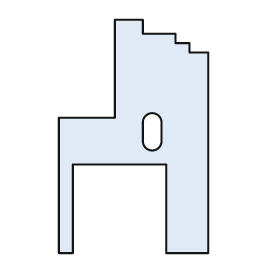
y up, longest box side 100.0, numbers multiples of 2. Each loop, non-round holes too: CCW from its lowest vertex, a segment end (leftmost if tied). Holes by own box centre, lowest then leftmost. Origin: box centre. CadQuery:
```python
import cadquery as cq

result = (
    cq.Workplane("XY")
    .moveTo(-32.0, -50.0)
    .lineTo(-26.0, -50.0)
    .lineTo(-26.0, -12.0)
    .lineTo(14.0, -12.0)
    .lineTo(14.0, -50.0)
    .lineTo(32.0, -50.0)
    .lineTo(32.0, 36.0)
    .lineTo(24.0, 36.0)
    .lineTo(24.0, 40.0)
    .lineTo(18.0, 40.0)
    .lineTo(18.0, 44.0)
    .lineTo(4.0, 44.0)
    .lineTo(4.0, 50.0)
    .lineTo(-8.0, 50.0)
    .lineTo(-8.0, 8.0)
    .lineTo(-32.0, 8.0)
    .close()
    .moveTo(4.0, -2.0)
    .threePointArc((8.0, -6.0), (12.0, -2.0))
    .lineTo(12.0, 6.0)
    .threePointArc((8.0, 10.0), (4.0, 6.0))
    .close()
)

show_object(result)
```